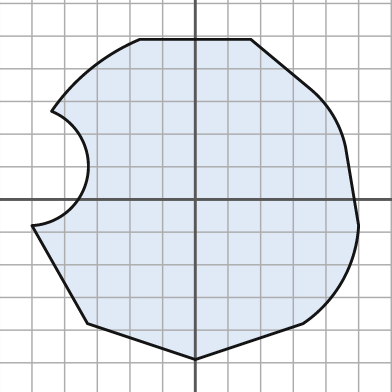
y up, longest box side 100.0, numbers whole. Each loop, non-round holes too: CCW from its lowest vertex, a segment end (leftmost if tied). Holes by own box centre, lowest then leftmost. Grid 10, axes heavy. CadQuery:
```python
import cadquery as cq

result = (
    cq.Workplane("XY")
    .moveTo(0.0, -49.0)
    .lineTo(33.0, -38.0)
    .threePointArc((45.0, -25.0), (50.0, -8.0))
    .lineTo(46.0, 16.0)
    .threePointArc((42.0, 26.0), (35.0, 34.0))
    .lineTo(17.0, 49.0)
    .lineTo(-17.0, 49.0)
    .threePointArc((-32.0, 40.0), (-44.0, 27.0))
    .threePointArc((-33.0, 7.0), (-50.0, -8.0))
    .lineTo(-33.0, -38.0)
    .close()
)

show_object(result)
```